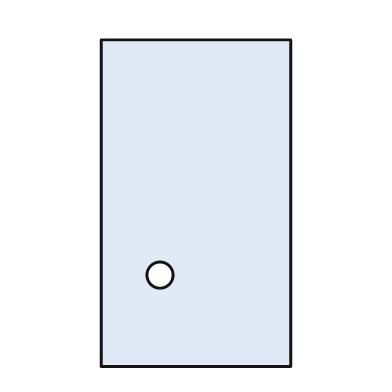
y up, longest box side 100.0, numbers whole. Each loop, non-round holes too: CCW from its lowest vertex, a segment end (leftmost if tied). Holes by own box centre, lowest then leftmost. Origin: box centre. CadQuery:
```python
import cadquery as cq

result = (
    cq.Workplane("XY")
    .moveTo(-29.0, -50.0)
    .lineTo(29.0, -50.0)
    .lineTo(29.0, 50.0)
    .lineTo(-29.0, 50.0)
    .close()
    .moveTo(-11.0, -22.0)
    .circle(4.0)
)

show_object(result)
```